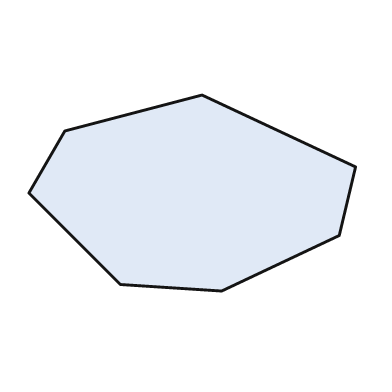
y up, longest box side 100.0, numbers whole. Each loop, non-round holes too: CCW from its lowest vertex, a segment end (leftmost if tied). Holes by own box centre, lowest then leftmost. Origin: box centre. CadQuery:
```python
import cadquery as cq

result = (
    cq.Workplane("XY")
    .moveTo(9.0, -30.0)
    .lineTo(45.0, -13.0)
    .lineTo(50.0, 8.0)
    .lineTo(3.0, 30.0)
    .lineTo(-39.0, 19.0)
    .lineTo(-50.0, 0.0)
    .lineTo(-22.0, -28.0)
    .close()
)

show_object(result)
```